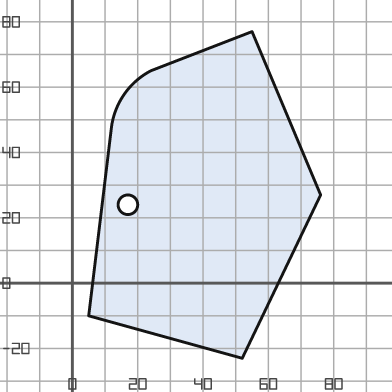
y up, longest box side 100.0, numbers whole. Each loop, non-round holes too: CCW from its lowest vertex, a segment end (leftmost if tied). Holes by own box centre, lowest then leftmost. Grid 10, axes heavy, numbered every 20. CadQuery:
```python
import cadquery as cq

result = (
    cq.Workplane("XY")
    .moveTo(52.0, -23.0)
    .lineTo(76.0, 27.0)
    .lineTo(55.0, 77.0)
    .lineTo(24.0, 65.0)
    .threePointArc((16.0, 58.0), (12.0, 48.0))
    .lineTo(5.0, -10.0)
    .close()
    .moveTo(17.0, 24.0)
    .circle(3.0)
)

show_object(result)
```